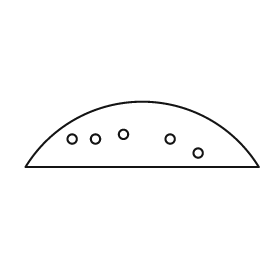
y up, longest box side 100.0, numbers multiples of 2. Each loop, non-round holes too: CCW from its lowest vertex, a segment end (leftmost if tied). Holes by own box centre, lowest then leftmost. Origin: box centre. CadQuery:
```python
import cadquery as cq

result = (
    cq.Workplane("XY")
    .moveTo(-50.0, -14.0)
    .lineTo(50.0, -14.0)
    .threePointArc((0.0, 14.0), (-50.0, -14.0))
    .close()
    .moveTo(24.0, -8.0)
    .circle(2.0)
    .moveTo(-30.0, -2.0)
    .circle(2.0)
    .moveTo(-20.0, -2.0)
    .circle(2.0)
    .moveTo(12.0, -2.0)
    .circle(2.0)
    .moveTo(-8.0, 0.0)
    .circle(2.0)
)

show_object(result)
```